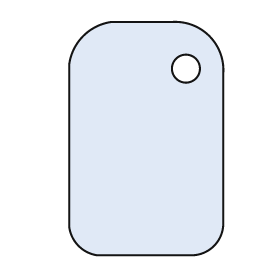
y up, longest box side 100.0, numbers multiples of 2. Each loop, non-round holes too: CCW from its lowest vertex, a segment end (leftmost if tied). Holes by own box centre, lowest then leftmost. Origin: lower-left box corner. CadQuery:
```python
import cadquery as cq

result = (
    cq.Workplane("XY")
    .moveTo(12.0, 0.0)
    .lineTo(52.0, 0.0)
    .threePointArc((62.0, 4.0), (66.0, 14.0))
    .lineTo(66.0, 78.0)
    .threePointArc((60.0, 94.0), (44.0, 100.0))
    .lineTo(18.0, 100.0)
    .threePointArc((6.0, 94.0), (0.0, 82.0))
    .lineTo(0.0, 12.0)
    .threePointArc((4.0, 4.0), (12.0, 0.0))
    .close()
    .moveTo(50.0, 80.0)
    .circle(6.0)
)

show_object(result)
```